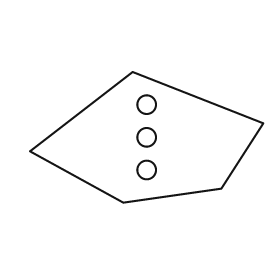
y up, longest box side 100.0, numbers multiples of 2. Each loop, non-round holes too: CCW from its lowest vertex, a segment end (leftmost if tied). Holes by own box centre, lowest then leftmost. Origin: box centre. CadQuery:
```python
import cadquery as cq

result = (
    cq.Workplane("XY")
    .moveTo(-10.0, -28.0)
    .lineTo(32.0, -22.0)
    .lineTo(50.0, 6.0)
    .lineTo(-6.0, 28.0)
    .lineTo(-50.0, -6.0)
    .close()
    .moveTo(0.0, -14.0)
    .circle(4.0)
    .moveTo(0.0, 0.0)
    .circle(4.0)
    .moveTo(0.0, 14.0)
    .circle(4.0)
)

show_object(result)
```